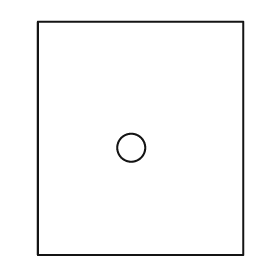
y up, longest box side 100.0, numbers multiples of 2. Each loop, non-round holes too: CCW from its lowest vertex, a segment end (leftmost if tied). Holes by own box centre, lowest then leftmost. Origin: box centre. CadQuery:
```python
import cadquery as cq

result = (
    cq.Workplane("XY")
    .moveTo(-44.0, -50.0)
    .lineTo(44.0, -50.0)
    .lineTo(44.0, 50.0)
    .lineTo(-44.0, 50.0)
    .close()
    .moveTo(-4.0, -4.0)
    .circle(6.0)
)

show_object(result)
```